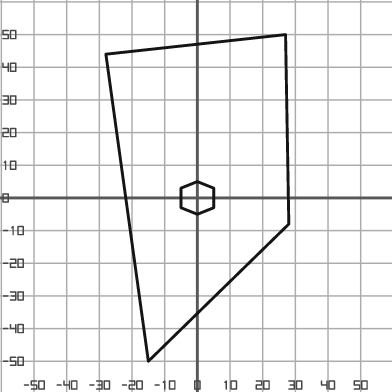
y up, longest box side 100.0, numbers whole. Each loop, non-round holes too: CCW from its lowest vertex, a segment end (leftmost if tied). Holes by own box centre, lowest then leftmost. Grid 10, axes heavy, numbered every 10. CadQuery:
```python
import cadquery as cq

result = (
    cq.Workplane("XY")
    .moveTo(-15.0, -50.0)
    .lineTo(28.0, -8.0)
    .lineTo(27.0, 50.0)
    .lineTo(-28.0, 44.0)
    .close()
    .moveTo(0.0, -5.0)
    .lineTo(5.0, -3.0)
    .lineTo(5.0, 3.0)
    .lineTo(0.0, 5.0)
    .lineTo(-5.0, 3.0)
    .lineTo(-5.0, -3.0)
    .close()
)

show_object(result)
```